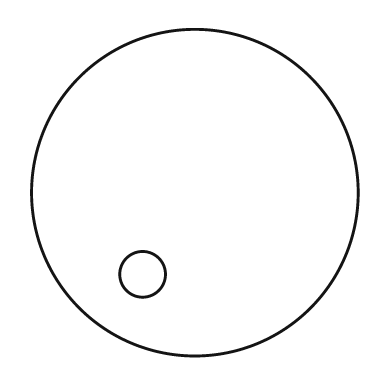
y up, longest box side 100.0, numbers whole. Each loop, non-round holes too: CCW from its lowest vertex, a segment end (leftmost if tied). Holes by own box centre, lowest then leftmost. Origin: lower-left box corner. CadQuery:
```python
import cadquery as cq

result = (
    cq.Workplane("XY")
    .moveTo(50.0, 50.0)
    .circle(50.0)
    .moveTo(34.0, 25.0)
    .circle(7.0)
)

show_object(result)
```